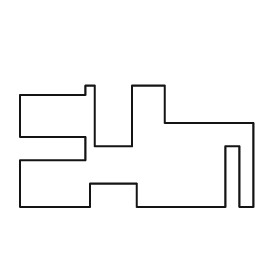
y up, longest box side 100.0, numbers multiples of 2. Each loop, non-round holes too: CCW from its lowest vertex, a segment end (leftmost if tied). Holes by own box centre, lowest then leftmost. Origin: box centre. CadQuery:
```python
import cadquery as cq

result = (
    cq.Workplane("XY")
    .moveTo(-50.0, -26.0)
    .lineTo(-20.0, -26.0)
    .lineTo(-20.0, -16.0)
    .lineTo(0.0, -16.0)
    .lineTo(0.0, -26.0)
    .lineTo(38.0, -26.0)
    .lineTo(38.0, 0.0)
    .lineTo(44.0, 0.0)
    .lineTo(44.0, -26.0)
    .lineTo(50.0, -26.0)
    .lineTo(50.0, 10.0)
    .lineTo(12.0, 10.0)
    .lineTo(12.0, 26.0)
    .lineTo(-2.0, 26.0)
    .lineTo(-2.0, 0.0)
    .lineTo(-18.0, 0.0)
    .lineTo(-18.0, 26.0)
    .lineTo(-22.0, 26.0)
    .lineTo(-22.0, 22.0)
    .lineTo(-50.0, 22.0)
    .lineTo(-50.0, 4.0)
    .lineTo(-22.0, 4.0)
    .lineTo(-22.0, -6.0)
    .lineTo(-50.0, -6.0)
    .close()
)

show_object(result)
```